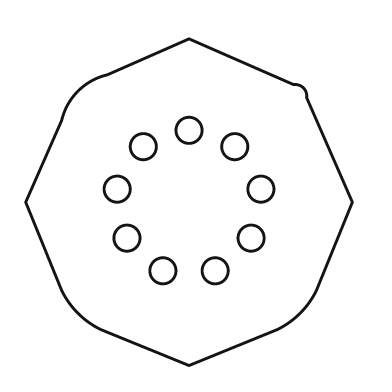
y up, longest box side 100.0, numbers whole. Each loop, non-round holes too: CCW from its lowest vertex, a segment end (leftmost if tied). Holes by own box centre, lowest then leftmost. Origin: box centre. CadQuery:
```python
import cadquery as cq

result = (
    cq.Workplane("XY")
    .moveTo(0.0, -50.0)
    .lineTo(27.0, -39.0)
    .threePointArc((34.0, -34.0), (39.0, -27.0))
    .lineTo(50.0, 0.0)
    .lineTo(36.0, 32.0)
    .threePointArc((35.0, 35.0), (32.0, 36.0))
    .lineTo(0.0, 50.0)
    .lineTo(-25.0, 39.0)
    .threePointArc((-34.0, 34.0), (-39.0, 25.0))
    .lineTo(-50.0, 0.0)
    .lineTo(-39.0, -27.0)
    .threePointArc((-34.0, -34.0), (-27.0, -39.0))
    .close()
    .moveTo(-8.0, -21.0)
    .circle(4.0)
    .moveTo(8.0, -21.0)
    .circle(4.0)
    .moveTo(-19.0, -11.0)
    .circle(4.0)
    .moveTo(19.0, -11.0)
    .circle(4.0)
    .moveTo(-22.0, 4.0)
    .circle(4.0)
    .moveTo(22.0, 4.0)
    .circle(4.0)
    .moveTo(-14.0, 17.0)
    .circle(4.0)
    .moveTo(14.0, 17.0)
    .circle(4.0)
    .moveTo(0.0, 22.0)
    .circle(4.0)
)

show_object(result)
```